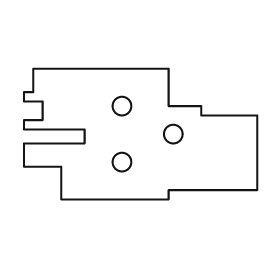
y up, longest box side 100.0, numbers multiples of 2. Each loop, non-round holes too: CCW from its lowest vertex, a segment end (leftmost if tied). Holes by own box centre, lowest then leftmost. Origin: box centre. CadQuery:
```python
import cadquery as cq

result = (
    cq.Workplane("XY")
    .moveTo(-34.0, -28.0)
    .lineTo(12.0, -28.0)
    .lineTo(12.0, -24.0)
    .lineTo(50.0, -24.0)
    .lineTo(50.0, 8.0)
    .lineTo(26.0, 8.0)
    .lineTo(26.0, 12.0)
    .lineTo(12.0, 12.0)
    .lineTo(12.0, 28.0)
    .lineTo(-46.0, 28.0)
    .lineTo(-46.0, 18.0)
    .lineTo(-50.0, 18.0)
    .lineTo(-50.0, 14.0)
    .lineTo(-42.0, 14.0)
    .lineTo(-42.0, 6.0)
    .lineTo(-50.0, 6.0)
    .lineTo(-50.0, 2.0)
    .lineTo(-24.0, 2.0)
    .lineTo(-24.0, -4.0)
    .lineTo(-50.0, -4.0)
    .lineTo(-50.0, -14.0)
    .lineTo(-34.0, -14.0)
    .close()
    .moveTo(-8.0, -12.0)
    .circle(4.0)
    .moveTo(14.0, 0.0)
    .circle(4.0)
    .moveTo(-8.0, 12.0)
    .circle(4.0)
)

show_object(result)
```